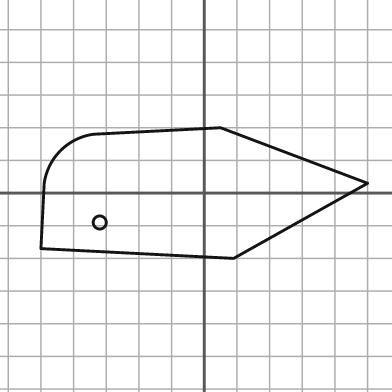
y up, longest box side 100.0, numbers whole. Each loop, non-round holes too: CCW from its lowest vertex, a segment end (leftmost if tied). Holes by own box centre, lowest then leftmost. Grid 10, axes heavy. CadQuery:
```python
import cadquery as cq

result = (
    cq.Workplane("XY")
    .moveTo(9.0, -20.0)
    .lineTo(50.0, 3.0)
    .lineTo(5.0, 20.0)
    .lineTo(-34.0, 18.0)
    .threePointArc((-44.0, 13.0), (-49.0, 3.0))
    .lineTo(-50.0, -17.0)
    .close()
    .moveTo(-32.0, -9.0)
    .circle(2.0)
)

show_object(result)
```